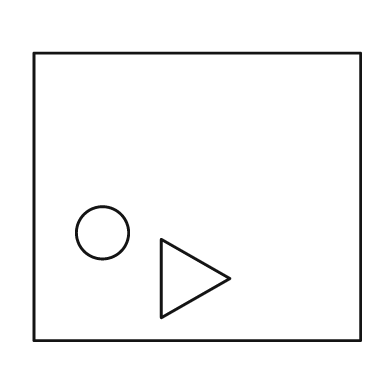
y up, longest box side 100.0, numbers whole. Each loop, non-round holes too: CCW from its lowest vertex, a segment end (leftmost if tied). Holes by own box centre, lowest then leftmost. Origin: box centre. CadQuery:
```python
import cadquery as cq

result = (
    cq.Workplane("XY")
    .moveTo(-50.0, -44.0)
    .lineTo(50.0, -44.0)
    .lineTo(50.0, 44.0)
    .lineTo(-50.0, 44.0)
    .close()
    .moveTo(-11.0, -37.0)
    .lineTo(10.0, -25.0)
    .lineTo(-11.0, -13.0)
    .close()
    .moveTo(-29.0, -11.0)
    .circle(8.0)
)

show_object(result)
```